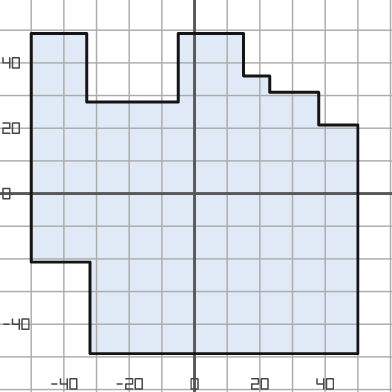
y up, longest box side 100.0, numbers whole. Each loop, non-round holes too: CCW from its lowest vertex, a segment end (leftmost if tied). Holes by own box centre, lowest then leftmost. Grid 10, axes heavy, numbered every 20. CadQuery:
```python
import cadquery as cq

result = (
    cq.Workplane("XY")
    .moveTo(-32.0, -49.0)
    .lineTo(50.0, -49.0)
    .lineTo(50.0, 21.0)
    .lineTo(38.0, 21.0)
    .lineTo(38.0, 31.0)
    .lineTo(23.0, 31.0)
    .lineTo(23.0, 36.0)
    .lineTo(15.0, 36.0)
    .lineTo(15.0, 49.0)
    .lineTo(-5.0, 49.0)
    .lineTo(-5.0, 28.0)
    .lineTo(-33.0, 28.0)
    .lineTo(-33.0, 49.0)
    .lineTo(-50.0, 49.0)
    .lineTo(-50.0, -21.0)
    .lineTo(-32.0, -21.0)
    .close()
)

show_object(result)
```